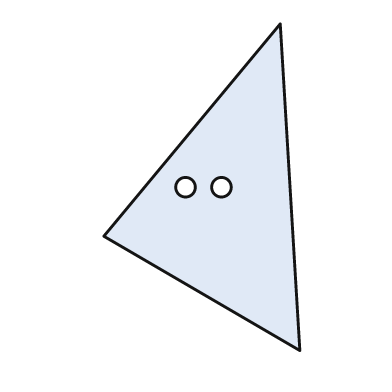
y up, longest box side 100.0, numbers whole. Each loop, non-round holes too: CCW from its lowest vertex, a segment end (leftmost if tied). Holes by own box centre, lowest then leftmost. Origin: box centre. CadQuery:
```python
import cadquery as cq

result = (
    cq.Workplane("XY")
    .moveTo(30.0, -50.0)
    .lineTo(24.0, 50.0)
    .lineTo(-30.0, -15.0)
    .close()
    .moveTo(-5.0, 0.0)
    .circle(3.0)
    .moveTo(6.0, 0.0)
    .circle(3.0)
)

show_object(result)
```